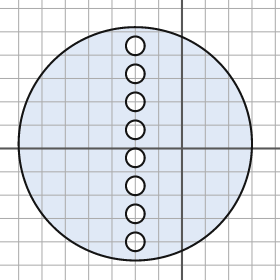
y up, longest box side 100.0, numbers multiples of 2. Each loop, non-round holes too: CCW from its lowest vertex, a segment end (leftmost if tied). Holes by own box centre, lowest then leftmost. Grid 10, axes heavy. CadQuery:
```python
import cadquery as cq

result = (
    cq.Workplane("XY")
    .moveTo(-20.0, 2.0)
    .circle(50.0)
    .moveTo(-20.0, -40.0)
    .circle(4.0)
    .moveTo(-20.0, -28.0)
    .circle(4.0)
    .moveTo(-20.0, -16.0)
    .circle(4.0)
    .moveTo(-20.0, -4.0)
    .circle(4.0)
    .moveTo(-20.0, 8.0)
    .circle(4.0)
    .moveTo(-20.0, 20.0)
    .circle(4.0)
    .moveTo(-20.0, 32.0)
    .circle(4.0)
    .moveTo(-20.0, 44.0)
    .circle(4.0)
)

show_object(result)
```